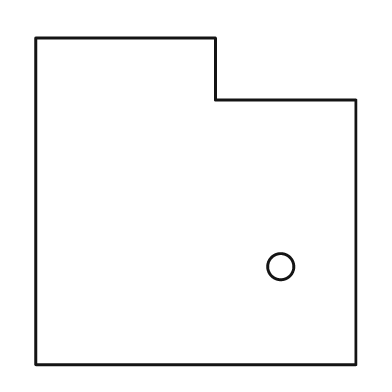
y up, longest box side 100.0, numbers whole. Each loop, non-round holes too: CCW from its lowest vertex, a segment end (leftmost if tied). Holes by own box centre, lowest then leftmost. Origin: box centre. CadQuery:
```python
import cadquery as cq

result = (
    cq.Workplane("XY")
    .moveTo(-49.0, -50.0)
    .lineTo(49.0, -50.0)
    .lineTo(49.0, 31.0)
    .lineTo(6.0, 31.0)
    .lineTo(6.0, 50.0)
    .lineTo(-49.0, 50.0)
    .close()
    .moveTo(26.0, -20.0)
    .circle(4.0)
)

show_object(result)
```